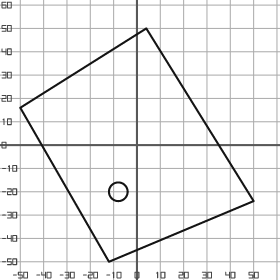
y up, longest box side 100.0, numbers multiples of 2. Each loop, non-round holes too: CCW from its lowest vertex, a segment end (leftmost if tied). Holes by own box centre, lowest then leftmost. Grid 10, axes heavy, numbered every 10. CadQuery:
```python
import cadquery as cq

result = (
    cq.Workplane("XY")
    .moveTo(-12.0, -50.0)
    .lineTo(50.0, -24.0)
    .lineTo(4.0, 50.0)
    .lineTo(-50.0, 16.0)
    .close()
    .moveTo(-8.0, -20.0)
    .circle(4.0)
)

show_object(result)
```